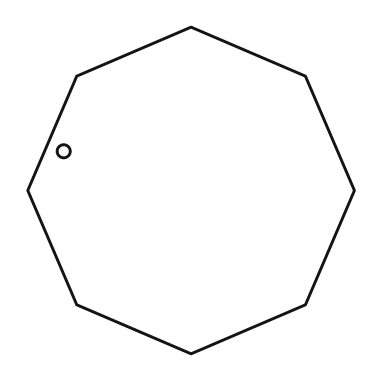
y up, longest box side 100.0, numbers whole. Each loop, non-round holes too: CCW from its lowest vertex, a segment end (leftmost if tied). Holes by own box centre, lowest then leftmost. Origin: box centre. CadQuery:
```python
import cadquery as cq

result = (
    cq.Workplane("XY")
    .moveTo(0.0, -50.0)
    .lineTo(35.0, -35.0)
    .lineTo(50.0, 0.0)
    .lineTo(35.0, 35.0)
    .lineTo(0.0, 50.0)
    .lineTo(-35.0, 35.0)
    .lineTo(-50.0, 0.0)
    .lineTo(-35.0, -35.0)
    .close()
    .moveTo(-39.0, 12.0)
    .circle(2.0)
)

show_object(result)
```